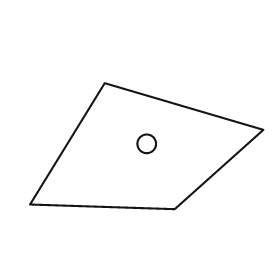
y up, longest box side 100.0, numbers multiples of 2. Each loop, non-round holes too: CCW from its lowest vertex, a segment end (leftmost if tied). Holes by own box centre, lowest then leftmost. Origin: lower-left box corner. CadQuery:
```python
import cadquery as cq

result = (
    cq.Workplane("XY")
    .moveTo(62.0, 0.0)
    .lineTo(100.0, 34.0)
    .lineTo(32.0, 54.0)
    .lineTo(0.0, 2.0)
    .close()
    .moveTo(50.0, 28.0)
    .circle(4.0)
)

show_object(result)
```